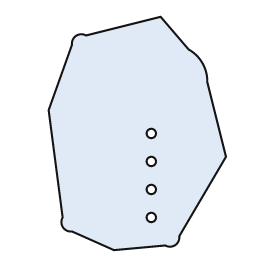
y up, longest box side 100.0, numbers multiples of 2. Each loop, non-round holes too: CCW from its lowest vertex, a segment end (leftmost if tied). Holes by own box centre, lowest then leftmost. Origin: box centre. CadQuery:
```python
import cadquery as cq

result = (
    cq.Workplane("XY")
    .moveTo(-10.0, -50.0)
    .lineTo(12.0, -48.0)
    .threePointArc((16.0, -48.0), (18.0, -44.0))
    .lineTo(38.0, -10.0)
    .lineTo(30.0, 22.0)
    .threePointArc((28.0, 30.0), (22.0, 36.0))
    .lineTo(10.0, 50.0)
    .lineTo(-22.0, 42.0)
    .threePointArc((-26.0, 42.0), (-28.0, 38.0))
    .lineTo(-38.0, 10.0)
    .lineTo(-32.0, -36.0)
    .threePointArc((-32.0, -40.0), (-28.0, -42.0))
    .close()
    .moveTo(6.0, -36.0)
    .circle(2.0)
    .moveTo(6.0, -24.0)
    .circle(2.0)
    .moveTo(6.0, -12.0)
    .circle(2.0)
    .moveTo(6.0, 0.0)
    .circle(2.0)
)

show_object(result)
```